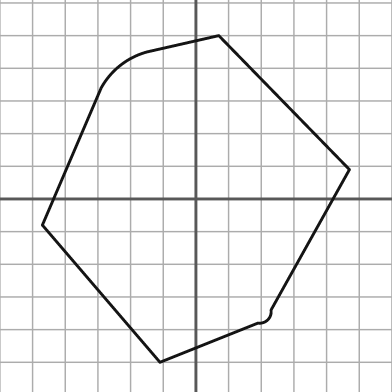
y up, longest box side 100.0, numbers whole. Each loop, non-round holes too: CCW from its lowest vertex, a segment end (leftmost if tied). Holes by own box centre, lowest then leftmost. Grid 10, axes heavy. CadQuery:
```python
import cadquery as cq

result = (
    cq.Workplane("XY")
    .moveTo(-11.0, -50.0)
    .lineTo(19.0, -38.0)
    .threePointArc((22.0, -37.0), (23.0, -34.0))
    .lineTo(47.0, 9.0)
    .lineTo(7.0, 50.0)
    .lineTo(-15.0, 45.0)
    .threePointArc((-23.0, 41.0), (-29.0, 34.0))
    .lineTo(-47.0, -8.0)
    .close()
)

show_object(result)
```